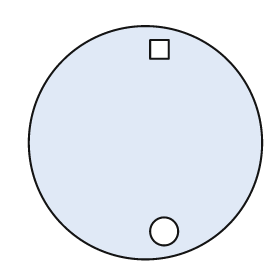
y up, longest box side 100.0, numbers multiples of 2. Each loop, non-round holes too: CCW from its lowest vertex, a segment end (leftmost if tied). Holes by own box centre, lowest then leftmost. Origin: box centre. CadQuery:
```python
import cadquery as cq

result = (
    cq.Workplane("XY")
    .moveTo(0.0, 0.0)
    .circle(50.0)
    .moveTo(8.0, -38.0)
    .circle(6.0)
    .moveTo(2.0, 36.0)
    .lineTo(10.0, 36.0)
    .lineTo(10.0, 44.0)
    .lineTo(2.0, 44.0)
    .close()
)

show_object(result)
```